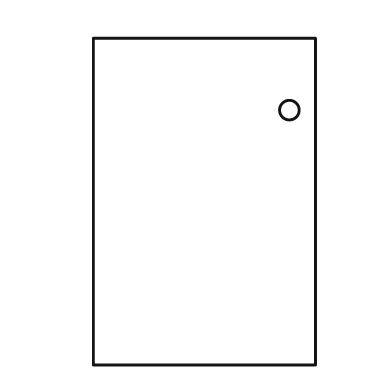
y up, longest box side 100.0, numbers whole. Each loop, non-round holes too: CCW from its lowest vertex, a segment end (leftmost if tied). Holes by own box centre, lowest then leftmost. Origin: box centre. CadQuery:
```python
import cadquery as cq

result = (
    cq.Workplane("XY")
    .moveTo(-34.0, -50.0)
    .lineTo(34.0, -50.0)
    .lineTo(34.0, 50.0)
    .lineTo(-34.0, 50.0)
    .close()
    .moveTo(26.0, 28.0)
    .circle(3.0)
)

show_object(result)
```